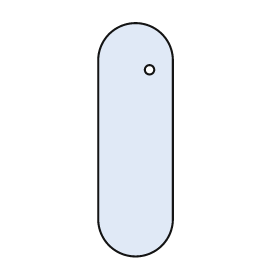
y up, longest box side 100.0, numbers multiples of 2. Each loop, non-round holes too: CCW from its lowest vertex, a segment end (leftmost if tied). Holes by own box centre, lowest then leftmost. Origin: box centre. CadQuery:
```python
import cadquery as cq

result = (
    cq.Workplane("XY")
    .moveTo(-16.0, -34.0)
    .threePointArc((0.0, -50.0), (16.0, -34.0))
    .lineTo(16.0, 34.0)
    .threePointArc((0.0, 50.0), (-16.0, 34.0))
    .close()
    .moveTo(6.0, 30.0)
    .circle(2.0)
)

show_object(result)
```